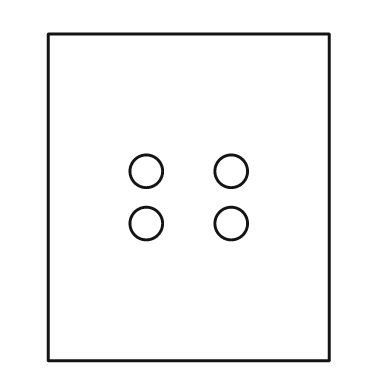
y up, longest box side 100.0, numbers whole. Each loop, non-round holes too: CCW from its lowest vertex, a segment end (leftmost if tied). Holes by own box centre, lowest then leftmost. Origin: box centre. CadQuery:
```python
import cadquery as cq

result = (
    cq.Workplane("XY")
    .moveTo(-43.0, -50.0)
    .lineTo(43.0, -50.0)
    .lineTo(43.0, 50.0)
    .lineTo(-43.0, 50.0)
    .close()
    .moveTo(-13.0, -8.0)
    .circle(5.0)
    .moveTo(13.0, -8.0)
    .circle(5.0)
    .moveTo(-13.0, 8.0)
    .circle(5.0)
    .moveTo(13.0, 8.0)
    .circle(5.0)
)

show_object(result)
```